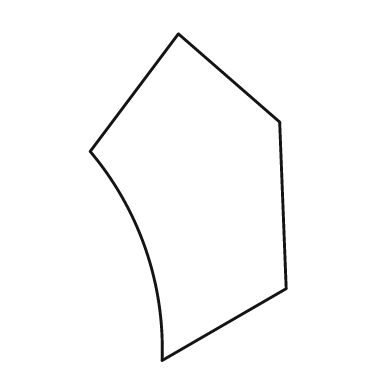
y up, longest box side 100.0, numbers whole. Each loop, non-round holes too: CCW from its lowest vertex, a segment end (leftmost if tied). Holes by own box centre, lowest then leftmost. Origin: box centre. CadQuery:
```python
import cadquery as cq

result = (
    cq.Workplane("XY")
    .moveTo(-8.0, -50.0)
    .lineTo(30.0, -28.0)
    .lineTo(28.0, 23.0)
    .lineTo(-3.0, 50.0)
    .lineTo(-30.0, 14.0)
    .threePointArc((-13.0, -16.0), (-8.0, -50.0))
    .close()
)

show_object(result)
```